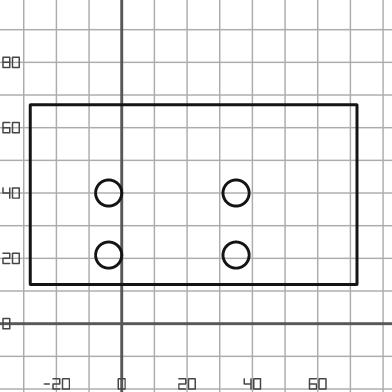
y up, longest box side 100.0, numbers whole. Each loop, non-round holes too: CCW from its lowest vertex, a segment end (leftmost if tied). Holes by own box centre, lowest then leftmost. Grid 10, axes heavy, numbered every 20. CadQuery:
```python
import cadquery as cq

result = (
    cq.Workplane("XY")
    .moveTo(-28.0, 12.0)
    .lineTo(72.0, 12.0)
    .lineTo(72.0, 67.0)
    .lineTo(-28.0, 67.0)
    .close()
    .moveTo(-4.0, 21.0)
    .circle(4.0)
    .moveTo(35.0, 21.0)
    .circle(4.0)
    .moveTo(-4.0, 40.0)
    .circle(4.0)
    .moveTo(35.0, 40.0)
    .circle(4.0)
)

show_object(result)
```